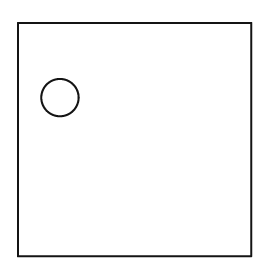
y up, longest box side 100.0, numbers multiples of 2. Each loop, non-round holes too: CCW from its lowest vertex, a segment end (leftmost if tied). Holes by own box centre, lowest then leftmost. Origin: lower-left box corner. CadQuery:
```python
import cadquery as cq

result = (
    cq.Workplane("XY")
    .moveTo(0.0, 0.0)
    .lineTo(100.0, 0.0)
    .lineTo(100.0, 100.0)
    .lineTo(0.0, 100.0)
    .close()
    .moveTo(18.0, 68.0)
    .circle(8.0)
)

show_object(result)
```